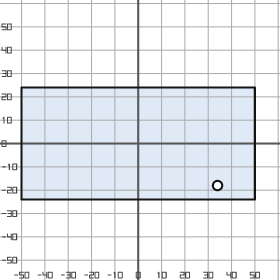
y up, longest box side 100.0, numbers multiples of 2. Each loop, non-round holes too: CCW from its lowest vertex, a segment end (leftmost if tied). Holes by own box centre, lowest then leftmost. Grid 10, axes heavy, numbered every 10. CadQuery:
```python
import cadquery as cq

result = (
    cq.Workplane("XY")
    .moveTo(-50.0, -24.0)
    .lineTo(50.0, -24.0)
    .lineTo(50.0, 24.0)
    .lineTo(-50.0, 24.0)
    .close()
    .moveTo(34.0, -18.0)
    .circle(2.0)
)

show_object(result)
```